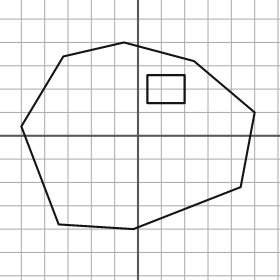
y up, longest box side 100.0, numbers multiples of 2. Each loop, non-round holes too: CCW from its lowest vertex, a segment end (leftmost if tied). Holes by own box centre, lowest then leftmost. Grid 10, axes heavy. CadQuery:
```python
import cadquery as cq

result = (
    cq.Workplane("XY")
    .moveTo(-2.0, -40.0)
    .lineTo(44.0, -22.0)
    .lineTo(50.0, 10.0)
    .lineTo(24.0, 32.0)
    .lineTo(-6.0, 40.0)
    .lineTo(-32.0, 34.0)
    .lineTo(-50.0, 4.0)
    .lineTo(-34.0, -38.0)
    .close()
    .moveTo(4.0, 14.0)
    .lineTo(20.0, 14.0)
    .lineTo(20.0, 26.0)
    .lineTo(4.0, 26.0)
    .close()
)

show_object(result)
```